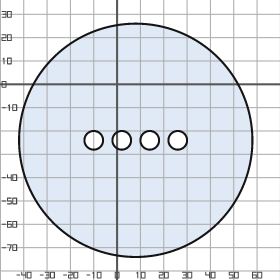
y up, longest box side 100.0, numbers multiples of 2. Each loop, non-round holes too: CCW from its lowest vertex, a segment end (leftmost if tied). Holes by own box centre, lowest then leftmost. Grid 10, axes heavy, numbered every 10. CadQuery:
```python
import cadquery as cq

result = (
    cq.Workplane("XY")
    .moveTo(8.0, -24.0)
    .circle(50.0)
    .moveTo(-10.0, -24.0)
    .circle(4.0)
    .moveTo(2.0, -24.0)
    .circle(4.0)
    .moveTo(14.0, -24.0)
    .circle(4.0)
    .moveTo(26.0, -24.0)
    .circle(4.0)
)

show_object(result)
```